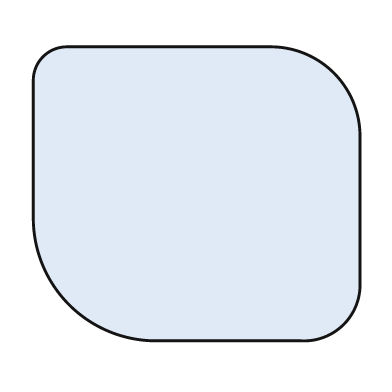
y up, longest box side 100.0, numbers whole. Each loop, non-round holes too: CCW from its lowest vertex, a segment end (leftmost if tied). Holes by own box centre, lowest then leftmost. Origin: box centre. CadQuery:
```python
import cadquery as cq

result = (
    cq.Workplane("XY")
    .moveTo(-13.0, -45.0)
    .lineTo(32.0, -45.0)
    .threePointArc((45.0, -40.0), (50.0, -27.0))
    .lineTo(50.0, 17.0)
    .threePointArc((42.0, 37.0), (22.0, 45.0))
    .lineTo(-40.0, 45.0)
    .threePointArc((-47.0, 42.0), (-50.0, 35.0))
    .lineTo(-50.0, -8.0)
    .threePointArc((-39.0, -34.0), (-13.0, -45.0))
    .close()
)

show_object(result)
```